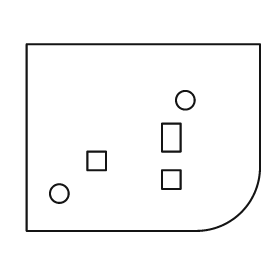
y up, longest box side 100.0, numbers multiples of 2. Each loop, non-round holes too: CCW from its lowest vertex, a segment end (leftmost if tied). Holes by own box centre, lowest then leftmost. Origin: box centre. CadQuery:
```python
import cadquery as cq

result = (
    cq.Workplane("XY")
    .moveTo(-50.0, -40.0)
    .lineTo(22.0, -40.0)
    .threePointArc((42.0, -32.0), (50.0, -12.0))
    .lineTo(50.0, 40.0)
    .lineTo(-50.0, 40.0)
    .close()
    .moveTo(-36.0, -24.0)
    .circle(4.0)
    .moveTo(8.0, -22.0)
    .lineTo(16.0, -22.0)
    .lineTo(16.0, -14.0)
    .lineTo(8.0, -14.0)
    .close()
    .moveTo(-24.0, -14.0)
    .lineTo(-16.0, -14.0)
    .lineTo(-16.0, -6.0)
    .lineTo(-24.0, -6.0)
    .close()
    .moveTo(8.0, -6.0)
    .lineTo(16.0, -6.0)
    .lineTo(16.0, 6.0)
    .lineTo(8.0, 6.0)
    .close()
    .moveTo(18.0, 16.0)
    .circle(4.0)
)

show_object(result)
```